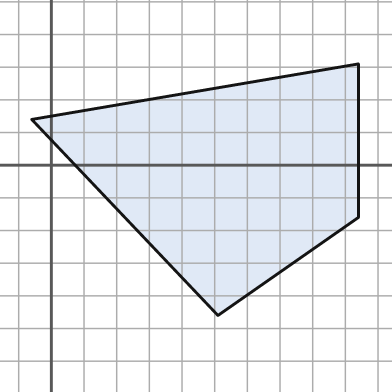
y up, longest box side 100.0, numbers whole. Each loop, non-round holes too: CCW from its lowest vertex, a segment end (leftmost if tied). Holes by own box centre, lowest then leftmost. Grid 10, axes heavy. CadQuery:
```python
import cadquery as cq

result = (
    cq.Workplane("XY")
    .moveTo(51.0, -46.0)
    .lineTo(94.0, -16.0)
    .lineTo(94.0, 31.0)
    .lineTo(-6.0, 14.0)
    .close()
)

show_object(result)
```